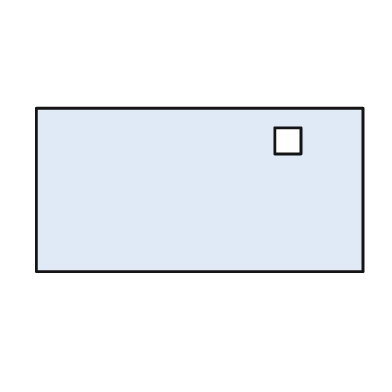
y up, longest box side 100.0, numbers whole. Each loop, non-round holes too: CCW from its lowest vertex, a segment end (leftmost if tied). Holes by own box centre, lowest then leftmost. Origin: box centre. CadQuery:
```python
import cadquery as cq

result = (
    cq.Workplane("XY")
    .moveTo(-50.0, -25.0)
    .lineTo(50.0, -25.0)
    .lineTo(50.0, 25.0)
    .lineTo(-50.0, 25.0)
    .close()
    .moveTo(23.0, 11.0)
    .lineTo(31.0, 11.0)
    .lineTo(31.0, 19.0)
    .lineTo(23.0, 19.0)
    .close()
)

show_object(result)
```